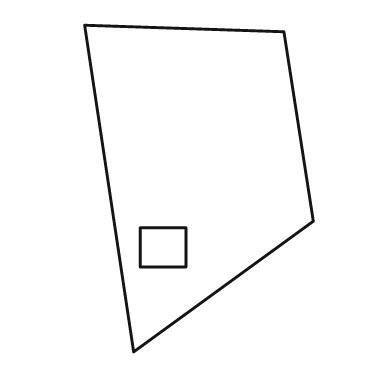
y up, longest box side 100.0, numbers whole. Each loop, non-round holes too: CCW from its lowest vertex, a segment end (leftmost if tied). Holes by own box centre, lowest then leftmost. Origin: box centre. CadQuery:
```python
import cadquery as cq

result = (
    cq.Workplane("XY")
    .moveTo(-20.0, -50.0)
    .lineTo(35.0, -10.0)
    .lineTo(26.0, 48.0)
    .lineTo(-35.0, 50.0)
    .close()
    .moveTo(-18.0, -24.0)
    .lineTo(-4.0, -24.0)
    .lineTo(-4.0, -12.0)
    .lineTo(-18.0, -12.0)
    .close()
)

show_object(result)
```